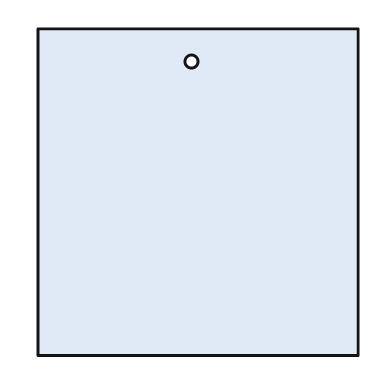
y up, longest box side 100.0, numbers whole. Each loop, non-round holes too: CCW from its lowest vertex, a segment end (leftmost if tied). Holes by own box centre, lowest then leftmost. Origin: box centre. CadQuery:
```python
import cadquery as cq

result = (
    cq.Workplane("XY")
    .moveTo(-49.0, -50.0)
    .lineTo(49.0, -50.0)
    .lineTo(49.0, 50.0)
    .lineTo(-49.0, 50.0)
    .close()
    .moveTo(-2.0, 40.0)
    .circle(2.0)
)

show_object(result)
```